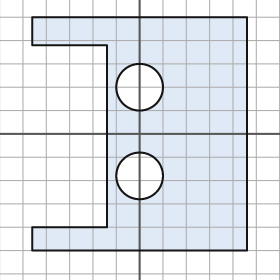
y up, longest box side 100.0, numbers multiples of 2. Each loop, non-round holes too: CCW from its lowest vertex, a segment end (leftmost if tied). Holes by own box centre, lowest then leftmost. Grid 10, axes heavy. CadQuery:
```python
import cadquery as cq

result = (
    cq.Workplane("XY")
    .moveTo(-46.0, -50.0)
    .lineTo(46.0, -50.0)
    .lineTo(46.0, 50.0)
    .lineTo(-46.0, 50.0)
    .lineTo(-46.0, 38.0)
    .lineTo(-14.0, 38.0)
    .lineTo(-14.0, -40.0)
    .lineTo(-46.0, -40.0)
    .close()
    .moveTo(0.0, -18.0)
    .circle(10.0)
    .moveTo(0.0, 20.0)
    .circle(10.0)
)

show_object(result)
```